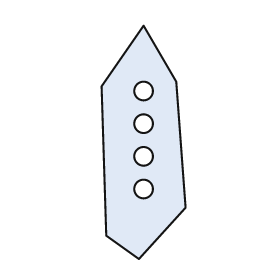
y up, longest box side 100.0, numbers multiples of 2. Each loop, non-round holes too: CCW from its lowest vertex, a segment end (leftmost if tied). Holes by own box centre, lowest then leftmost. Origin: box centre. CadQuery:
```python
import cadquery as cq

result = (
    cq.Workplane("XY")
    .moveTo(-2.0, -50.0)
    .lineTo(18.0, -28.0)
    .lineTo(14.0, 26.0)
    .lineTo(0.0, 50.0)
    .lineTo(-18.0, 24.0)
    .lineTo(-16.0, -40.0)
    .close()
    .moveTo(0.0, -20.0)
    .circle(4.0)
    .moveTo(0.0, -6.0)
    .circle(4.0)
    .moveTo(0.0, 8.0)
    .circle(4.0)
    .moveTo(0.0, 22.0)
    .circle(4.0)
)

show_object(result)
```